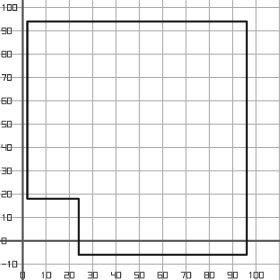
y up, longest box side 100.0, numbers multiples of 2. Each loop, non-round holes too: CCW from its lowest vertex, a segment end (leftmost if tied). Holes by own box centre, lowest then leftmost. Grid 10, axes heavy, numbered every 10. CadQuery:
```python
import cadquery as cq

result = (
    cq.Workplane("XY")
    .moveTo(24.0, -6.0)
    .lineTo(96.0, -6.0)
    .lineTo(96.0, 94.0)
    .lineTo(2.0, 94.0)
    .lineTo(2.0, 18.0)
    .lineTo(24.0, 18.0)
    .close()
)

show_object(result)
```